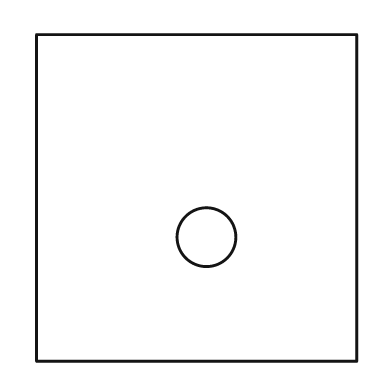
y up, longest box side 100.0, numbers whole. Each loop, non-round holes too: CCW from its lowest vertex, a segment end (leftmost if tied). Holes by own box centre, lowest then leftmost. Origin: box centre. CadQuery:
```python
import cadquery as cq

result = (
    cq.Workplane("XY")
    .moveTo(-49.0, -50.0)
    .lineTo(49.0, -50.0)
    .lineTo(49.0, 50.0)
    .lineTo(-49.0, 50.0)
    .close()
    .moveTo(3.0, -12.0)
    .circle(9.0)
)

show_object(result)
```